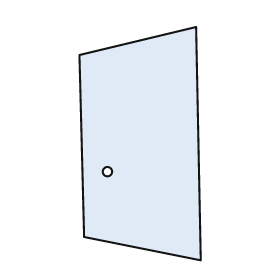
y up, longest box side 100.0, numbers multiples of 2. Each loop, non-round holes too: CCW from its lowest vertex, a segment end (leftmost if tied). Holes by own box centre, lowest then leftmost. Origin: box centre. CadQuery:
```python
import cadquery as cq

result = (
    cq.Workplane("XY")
    .moveTo(26.0, -50.0)
    .lineTo(24.0, 50.0)
    .lineTo(-26.0, 38.0)
    .lineTo(-24.0, -40.0)
    .close()
    .moveTo(-14.0, -12.0)
    .circle(2.0)
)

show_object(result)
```